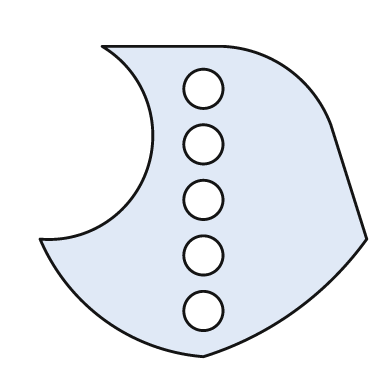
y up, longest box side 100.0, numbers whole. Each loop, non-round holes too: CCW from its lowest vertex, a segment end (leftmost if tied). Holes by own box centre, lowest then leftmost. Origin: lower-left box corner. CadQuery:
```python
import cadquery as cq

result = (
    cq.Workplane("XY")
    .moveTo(50.0, 0.0)
    .threePointArc((78.0, 14.0), (100.0, 36.0))
    .lineTo(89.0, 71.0)
    .threePointArc((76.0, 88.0), (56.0, 95.0))
    .lineTo(19.0, 95.0)
    .threePointArc((33.0, 58.0), (0.0, 36.0))
    .threePointArc((20.0, 11.0), (50.0, 0.0))
    .close()
    .moveTo(50.0, 14.0)
    .circle(6.0)
    .moveTo(50.0, 31.0)
    .circle(6.0)
    .moveTo(50.0, 48.0)
    .circle(6.0)
    .moveTo(50.0, 65.0)
    .circle(6.0)
    .moveTo(50.0, 82.0)
    .circle(6.0)
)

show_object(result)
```